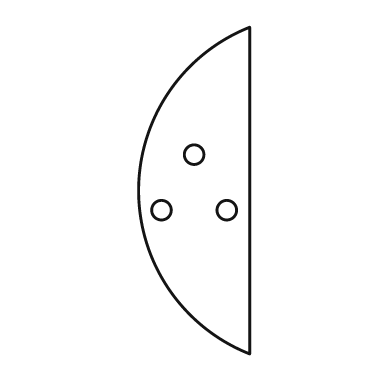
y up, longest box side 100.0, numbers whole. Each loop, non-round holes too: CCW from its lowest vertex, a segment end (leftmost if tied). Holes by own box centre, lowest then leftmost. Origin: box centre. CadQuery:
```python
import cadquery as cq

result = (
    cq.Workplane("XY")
    .moveTo(17.0, -50.0)
    .lineTo(17.0, 50.0)
    .threePointArc((-17.0, 0.0), (17.0, -50.0))
    .close()
    .moveTo(-10.0, -6.0)
    .circle(3.0)
    .moveTo(10.0, -6.0)
    .circle(3.0)
    .moveTo(0.0, 11.0)
    .circle(3.0)
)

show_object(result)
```